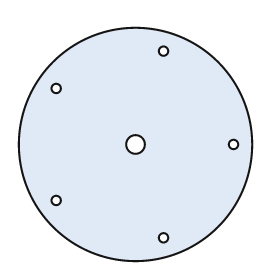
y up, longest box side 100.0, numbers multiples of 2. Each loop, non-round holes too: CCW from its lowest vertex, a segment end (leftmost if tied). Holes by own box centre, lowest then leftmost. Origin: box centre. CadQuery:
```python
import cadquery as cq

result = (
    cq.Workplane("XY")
    .moveTo(0.0, 0.0)
    .circle(50.0)
    .moveTo(12.0, -40.0)
    .circle(2.0)
    .moveTo(-34.0, -24.0)
    .circle(2.0)
    .moveTo(0.0, 0.0)
    .circle(4.0)
    .moveTo(42.0, 0.0)
    .circle(2.0)
    .moveTo(-34.0, 24.0)
    .circle(2.0)
    .moveTo(12.0, 40.0)
    .circle(2.0)
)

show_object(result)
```